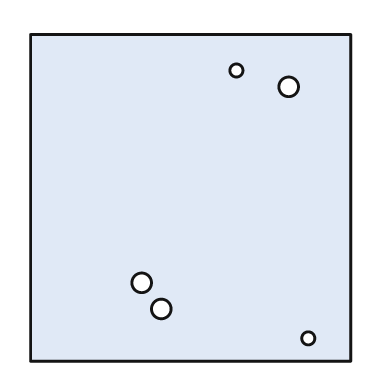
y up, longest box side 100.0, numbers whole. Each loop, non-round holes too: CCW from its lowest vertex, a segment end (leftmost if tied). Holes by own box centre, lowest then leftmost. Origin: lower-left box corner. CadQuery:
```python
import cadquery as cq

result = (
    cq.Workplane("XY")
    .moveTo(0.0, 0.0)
    .lineTo(98.0, 0.0)
    .lineTo(98.0, 100.0)
    .lineTo(0.0, 100.0)
    .close()
    .moveTo(85.0, 7.0)
    .circle(2.0)
    .moveTo(40.0, 16.0)
    .circle(3.0)
    .moveTo(34.0, 24.0)
    .circle(3.0)
    .moveTo(79.0, 84.0)
    .circle(3.0)
    .moveTo(63.0, 89.0)
    .circle(2.0)
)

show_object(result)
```